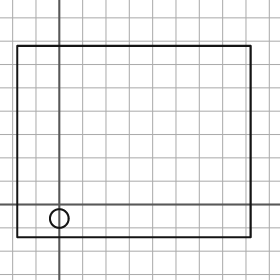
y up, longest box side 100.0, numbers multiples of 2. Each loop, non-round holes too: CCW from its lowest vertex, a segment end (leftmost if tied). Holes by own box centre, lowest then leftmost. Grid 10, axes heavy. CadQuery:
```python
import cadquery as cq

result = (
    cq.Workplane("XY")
    .moveTo(-18.0, -14.0)
    .lineTo(82.0, -14.0)
    .lineTo(82.0, 68.0)
    .lineTo(-18.0, 68.0)
    .close()
    .moveTo(0.0, -6.0)
    .circle(4.0)
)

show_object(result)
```